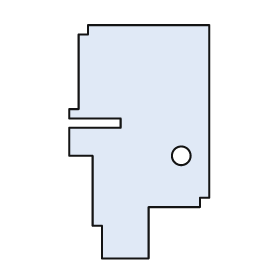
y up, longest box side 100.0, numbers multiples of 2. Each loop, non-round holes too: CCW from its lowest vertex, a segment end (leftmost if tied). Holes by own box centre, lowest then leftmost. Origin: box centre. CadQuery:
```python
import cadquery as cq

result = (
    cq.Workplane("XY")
    .moveTo(-16.0, -50.0)
    .lineTo(4.0, -50.0)
    .lineTo(4.0, -28.0)
    .lineTo(26.0, -28.0)
    .lineTo(26.0, -24.0)
    .lineTo(30.0, -24.0)
    .lineTo(30.0, 50.0)
    .lineTo(-22.0, 50.0)
    .lineTo(-22.0, 46.0)
    .lineTo(-26.0, 46.0)
    .lineTo(-26.0, 14.0)
    .lineTo(-30.0, 14.0)
    .lineTo(-30.0, 10.0)
    .lineTo(-8.0, 10.0)
    .lineTo(-8.0, 6.0)
    .lineTo(-30.0, 6.0)
    .lineTo(-30.0, -6.0)
    .lineTo(-20.0, -6.0)
    .lineTo(-20.0, -36.0)
    .lineTo(-16.0, -36.0)
    .close()
    .moveTo(18.0, -6.0)
    .circle(4.0)
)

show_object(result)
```